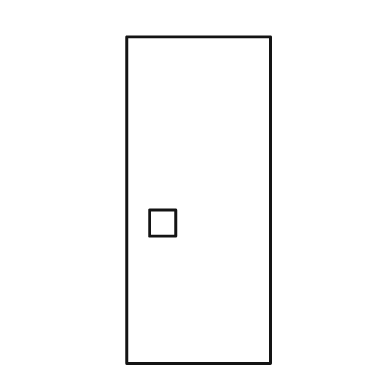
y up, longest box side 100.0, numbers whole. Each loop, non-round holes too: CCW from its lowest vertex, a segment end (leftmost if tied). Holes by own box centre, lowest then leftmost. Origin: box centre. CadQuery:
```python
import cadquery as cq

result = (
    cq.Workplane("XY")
    .moveTo(-22.0, -50.0)
    .lineTo(22.0, -50.0)
    .lineTo(22.0, 50.0)
    .lineTo(-22.0, 50.0)
    .close()
    .moveTo(-15.0, -11.0)
    .lineTo(-7.0, -11.0)
    .lineTo(-7.0, -3.0)
    .lineTo(-15.0, -3.0)
    .close()
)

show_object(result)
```